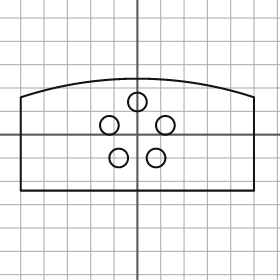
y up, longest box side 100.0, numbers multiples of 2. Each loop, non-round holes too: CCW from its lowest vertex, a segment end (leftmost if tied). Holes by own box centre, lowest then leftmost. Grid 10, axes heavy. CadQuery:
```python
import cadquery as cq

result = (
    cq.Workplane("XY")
    .moveTo(-50.0, -24.0)
    .lineTo(50.0, -24.0)
    .lineTo(50.0, 16.0)
    .threePointArc((0.0, 24.0), (-50.0, 16.0))
    .close()
    .moveTo(-8.0, -10.0)
    .circle(4.0)
    .moveTo(8.0, -10.0)
    .circle(4.0)
    .moveTo(-12.0, 4.0)
    .circle(4.0)
    .moveTo(12.0, 4.0)
    .circle(4.0)
    .moveTo(0.0, 14.0)
    .circle(4.0)
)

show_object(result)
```